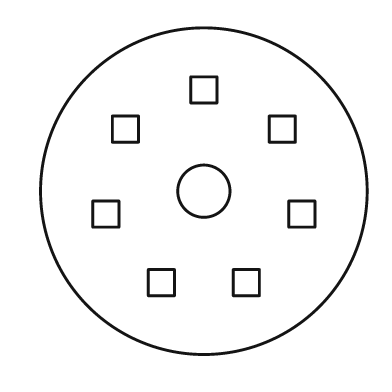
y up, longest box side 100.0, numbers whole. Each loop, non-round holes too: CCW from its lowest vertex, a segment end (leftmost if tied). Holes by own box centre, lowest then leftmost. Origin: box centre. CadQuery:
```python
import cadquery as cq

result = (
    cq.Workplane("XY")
    .moveTo(0.0, 0.0)
    .circle(50.0)
    .moveTo(-17.0, -32.0)
    .lineTo(-9.0, -32.0)
    .lineTo(-9.0, -24.0)
    .lineTo(-17.0, -24.0)
    .close()
    .moveTo(9.0, -32.0)
    .lineTo(17.0, -32.0)
    .lineTo(17.0, -24.0)
    .lineTo(9.0, -24.0)
    .close()
    .moveTo(-34.0, -11.0)
    .lineTo(-26.0, -11.0)
    .lineTo(-26.0, -3.0)
    .lineTo(-34.0, -3.0)
    .close()
    .moveTo(26.0, -11.0)
    .lineTo(34.0, -11.0)
    .lineTo(34.0, -3.0)
    .lineTo(26.0, -3.0)
    .close()
    .moveTo(0.0, 0.0)
    .circle(8.0)
    .moveTo(-28.0, 15.0)
    .lineTo(-20.0, 15.0)
    .lineTo(-20.0, 23.0)
    .lineTo(-28.0, 23.0)
    .close()
    .moveTo(20.0, 15.0)
    .lineTo(28.0, 15.0)
    .lineTo(28.0, 23.0)
    .lineTo(20.0, 23.0)
    .close()
    .moveTo(-4.0, 27.0)
    .lineTo(4.0, 27.0)
    .lineTo(4.0, 35.0)
    .lineTo(-4.0, 35.0)
    .close()
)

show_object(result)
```